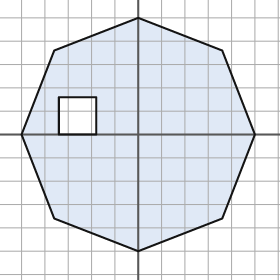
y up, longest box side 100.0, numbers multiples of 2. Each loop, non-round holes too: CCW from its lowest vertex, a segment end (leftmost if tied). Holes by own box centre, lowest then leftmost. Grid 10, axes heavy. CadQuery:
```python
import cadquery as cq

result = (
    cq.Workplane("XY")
    .moveTo(0.0, -50.0)
    .lineTo(36.0, -36.0)
    .lineTo(50.0, 0.0)
    .lineTo(36.0, 36.0)
    .lineTo(0.0, 50.0)
    .lineTo(-36.0, 36.0)
    .lineTo(-50.0, 0.0)
    .lineTo(-36.0, -36.0)
    .close()
    .moveTo(-34.0, 0.0)
    .lineTo(-18.0, 0.0)
    .lineTo(-18.0, 16.0)
    .lineTo(-34.0, 16.0)
    .close()
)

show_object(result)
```